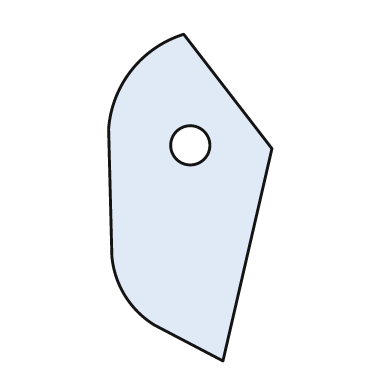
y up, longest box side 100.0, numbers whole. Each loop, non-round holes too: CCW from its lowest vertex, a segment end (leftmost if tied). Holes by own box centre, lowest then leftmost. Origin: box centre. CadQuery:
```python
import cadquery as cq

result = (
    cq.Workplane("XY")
    .moveTo(10.0, -50.0)
    .lineTo(25.0, 15.0)
    .lineTo(-2.0, 50.0)
    .threePointArc((-18.0, 39.0), (-25.0, 21.0))
    .lineTo(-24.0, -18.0)
    .threePointArc((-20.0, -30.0), (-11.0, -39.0))
    .close()
    .moveTo(0.0, 16.0)
    .circle(6.0)
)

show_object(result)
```